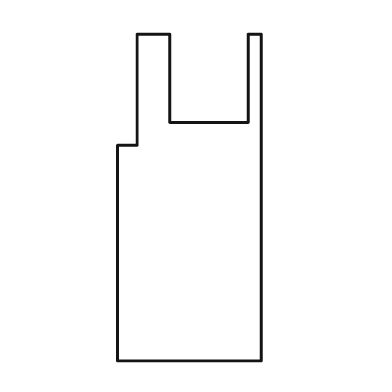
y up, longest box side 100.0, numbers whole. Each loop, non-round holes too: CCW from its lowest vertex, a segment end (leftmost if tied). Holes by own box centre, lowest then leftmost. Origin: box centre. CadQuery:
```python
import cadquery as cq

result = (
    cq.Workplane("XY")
    .moveTo(-22.0, -50.0)
    .lineTo(22.0, -50.0)
    .lineTo(22.0, 50.0)
    .lineTo(18.0, 50.0)
    .lineTo(18.0, 23.0)
    .lineTo(-6.0, 23.0)
    .lineTo(-6.0, 50.0)
    .lineTo(-16.0, 50.0)
    .lineTo(-16.0, 16.0)
    .lineTo(-22.0, 16.0)
    .close()
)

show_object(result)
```